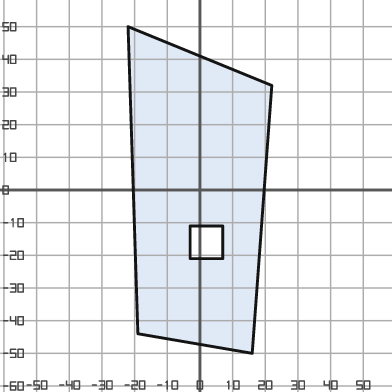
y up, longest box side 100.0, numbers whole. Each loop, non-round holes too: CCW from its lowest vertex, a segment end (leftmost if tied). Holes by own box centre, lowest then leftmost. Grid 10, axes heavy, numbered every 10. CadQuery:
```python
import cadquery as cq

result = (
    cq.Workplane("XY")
    .moveTo(16.0, -50.0)
    .lineTo(22.0, 32.0)
    .lineTo(-22.0, 50.0)
    .lineTo(-19.0, -44.0)
    .close()
    .moveTo(-3.0, -21.0)
    .lineTo(7.0, -21.0)
    .lineTo(7.0, -11.0)
    .lineTo(-3.0, -11.0)
    .close()
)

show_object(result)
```